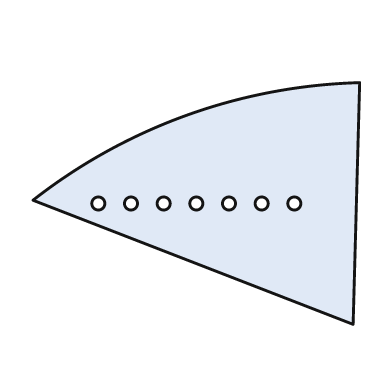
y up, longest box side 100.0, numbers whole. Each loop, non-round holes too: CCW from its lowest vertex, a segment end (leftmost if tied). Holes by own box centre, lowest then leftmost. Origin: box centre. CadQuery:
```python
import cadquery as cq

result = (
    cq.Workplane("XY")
    .moveTo(48.0, -37.0)
    .lineTo(50.0, 37.0)
    .threePointArc((-3.0, 27.0), (-50.0, 1.0))
    .close()
    .moveTo(-30.0, 0.0)
    .circle(2.0)
    .moveTo(-20.0, 0.0)
    .circle(2.0)
    .moveTo(-10.0, 0.0)
    .circle(2.0)
    .moveTo(0.0, 0.0)
    .circle(2.0)
    .moveTo(10.0, 0.0)
    .circle(2.0)
    .moveTo(20.0, 0.0)
    .circle(2.0)
    .moveTo(30.0, 0.0)
    .circle(2.0)
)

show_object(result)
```